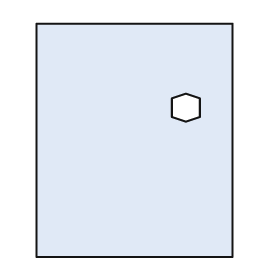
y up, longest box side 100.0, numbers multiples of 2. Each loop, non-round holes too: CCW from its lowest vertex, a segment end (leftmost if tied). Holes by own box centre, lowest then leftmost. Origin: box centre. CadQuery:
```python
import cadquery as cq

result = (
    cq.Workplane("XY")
    .moveTo(-42.0, -50.0)
    .lineTo(42.0, -50.0)
    .lineTo(42.0, 50.0)
    .lineTo(-42.0, 50.0)
    .close()
    .moveTo(22.0, 8.0)
    .lineTo(28.0, 10.0)
    .lineTo(28.0, 18.0)
    .lineTo(22.0, 20.0)
    .lineTo(16.0, 18.0)
    .lineTo(16.0, 10.0)
    .close()
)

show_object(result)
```